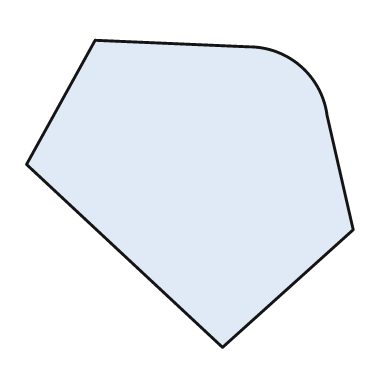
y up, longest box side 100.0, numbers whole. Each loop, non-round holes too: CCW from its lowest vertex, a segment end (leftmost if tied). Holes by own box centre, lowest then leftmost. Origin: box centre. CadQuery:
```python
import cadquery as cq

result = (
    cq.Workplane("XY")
    .moveTo(10.0, -47.0)
    .lineTo(50.0, -11.0)
    .lineTo(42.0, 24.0)
    .threePointArc((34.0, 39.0), (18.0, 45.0))
    .lineTo(-29.0, 47.0)
    .lineTo(-50.0, 9.0)
    .close()
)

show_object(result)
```